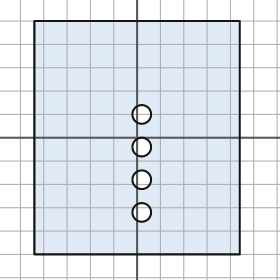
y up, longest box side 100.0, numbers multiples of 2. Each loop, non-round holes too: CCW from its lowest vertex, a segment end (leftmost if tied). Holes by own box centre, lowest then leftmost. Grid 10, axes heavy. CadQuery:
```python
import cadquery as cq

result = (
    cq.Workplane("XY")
    .moveTo(-44.0, -50.0)
    .lineTo(44.0, -50.0)
    .lineTo(44.0, 50.0)
    .lineTo(-44.0, 50.0)
    .close()
    .moveTo(2.0, -32.0)
    .circle(4.0)
    .moveTo(2.0, -18.0)
    .circle(4.0)
    .moveTo(2.0, -4.0)
    .circle(4.0)
    .moveTo(2.0, 10.0)
    .circle(4.0)
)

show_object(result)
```